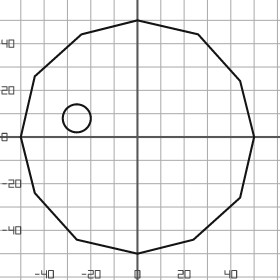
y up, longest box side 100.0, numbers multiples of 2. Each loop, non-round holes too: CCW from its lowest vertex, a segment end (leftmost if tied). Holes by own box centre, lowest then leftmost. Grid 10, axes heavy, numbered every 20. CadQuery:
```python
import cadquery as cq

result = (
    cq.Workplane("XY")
    .moveTo(0.0, -50.0)
    .lineTo(24.0, -44.0)
    .lineTo(44.0, -26.0)
    .lineTo(50.0, 0.0)
    .lineTo(44.0, 24.0)
    .lineTo(26.0, 44.0)
    .lineTo(0.0, 50.0)
    .lineTo(-24.0, 44.0)
    .lineTo(-44.0, 26.0)
    .lineTo(-50.0, 0.0)
    .lineTo(-44.0, -24.0)
    .lineTo(-26.0, -44.0)
    .close()
    .moveTo(-26.0, 8.0)
    .circle(6.0)
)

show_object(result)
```